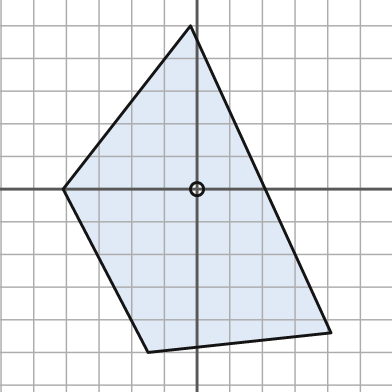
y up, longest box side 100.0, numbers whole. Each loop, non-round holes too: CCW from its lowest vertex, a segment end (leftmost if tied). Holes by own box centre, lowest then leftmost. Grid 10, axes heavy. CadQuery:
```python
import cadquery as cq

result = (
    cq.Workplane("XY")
    .moveTo(-15.0, -50.0)
    .lineTo(41.0, -44.0)
    .lineTo(-2.0, 50.0)
    .lineTo(-41.0, 0.0)
    .close()
    .moveTo(0.0, 0.0)
    .circle(2.0)
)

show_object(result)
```